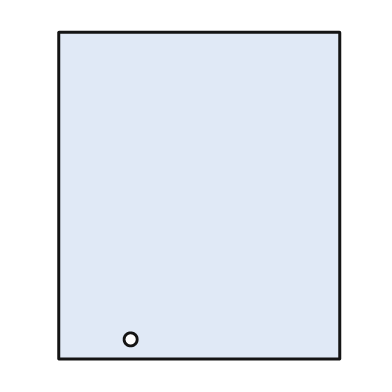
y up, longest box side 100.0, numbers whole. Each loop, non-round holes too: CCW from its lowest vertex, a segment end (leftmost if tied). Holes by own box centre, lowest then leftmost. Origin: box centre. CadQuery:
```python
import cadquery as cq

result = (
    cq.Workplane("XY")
    .moveTo(-43.0, -50.0)
    .lineTo(43.0, -50.0)
    .lineTo(43.0, 50.0)
    .lineTo(-43.0, 50.0)
    .close()
    .moveTo(-21.0, -44.0)
    .circle(2.0)
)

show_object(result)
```